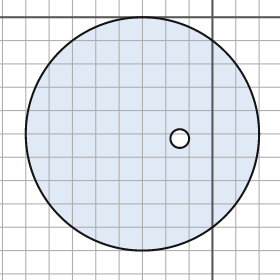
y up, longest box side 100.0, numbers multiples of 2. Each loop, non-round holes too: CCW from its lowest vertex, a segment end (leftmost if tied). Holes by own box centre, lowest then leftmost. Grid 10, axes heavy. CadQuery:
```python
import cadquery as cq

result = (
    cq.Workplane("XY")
    .moveTo(-30.0, -50.0)
    .circle(50.0)
    .moveTo(-14.0, -52.0)
    .circle(4.0)
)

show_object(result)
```